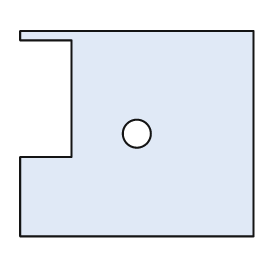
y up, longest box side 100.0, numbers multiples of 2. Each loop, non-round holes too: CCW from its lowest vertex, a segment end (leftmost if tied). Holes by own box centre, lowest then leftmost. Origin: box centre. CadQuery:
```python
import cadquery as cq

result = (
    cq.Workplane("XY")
    .moveTo(-50.0, -44.0)
    .lineTo(50.0, -44.0)
    .lineTo(50.0, 44.0)
    .lineTo(-50.0, 44.0)
    .lineTo(-50.0, 40.0)
    .lineTo(-28.0, 40.0)
    .lineTo(-28.0, -10.0)
    .lineTo(-50.0, -10.0)
    .close()
    .moveTo(0.0, 0.0)
    .circle(6.0)
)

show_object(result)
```